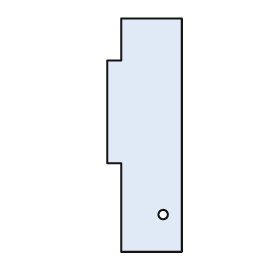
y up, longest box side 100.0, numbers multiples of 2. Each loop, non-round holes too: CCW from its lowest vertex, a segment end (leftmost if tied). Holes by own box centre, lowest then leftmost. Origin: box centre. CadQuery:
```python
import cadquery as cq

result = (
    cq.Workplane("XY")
    .moveTo(-10.0, -50.0)
    .lineTo(16.0, -50.0)
    .lineTo(16.0, 50.0)
    .lineTo(-10.0, 50.0)
    .lineTo(-10.0, 32.0)
    .lineTo(-16.0, 32.0)
    .lineTo(-16.0, -12.0)
    .lineTo(-10.0, -12.0)
    .close()
    .moveTo(8.0, -34.0)
    .circle(2.0)
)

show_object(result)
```